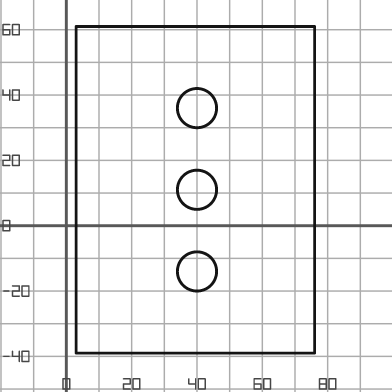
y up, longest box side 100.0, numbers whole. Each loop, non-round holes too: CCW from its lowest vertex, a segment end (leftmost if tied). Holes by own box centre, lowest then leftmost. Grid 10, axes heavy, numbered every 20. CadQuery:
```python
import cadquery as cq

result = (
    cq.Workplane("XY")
    .moveTo(3.0, -39.0)
    .lineTo(76.0, -39.0)
    .lineTo(76.0, 61.0)
    .lineTo(3.0, 61.0)
    .close()
    .moveTo(40.0, -14.0)
    .circle(6.0)
    .moveTo(40.0, 11.0)
    .circle(6.0)
    .moveTo(40.0, 36.0)
    .circle(6.0)
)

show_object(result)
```